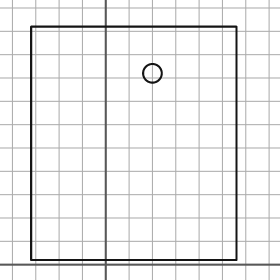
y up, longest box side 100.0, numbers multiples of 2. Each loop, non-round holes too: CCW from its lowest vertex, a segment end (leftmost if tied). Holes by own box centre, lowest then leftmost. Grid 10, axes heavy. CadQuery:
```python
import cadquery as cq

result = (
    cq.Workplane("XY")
    .moveTo(-32.0, 2.0)
    .lineTo(56.0, 2.0)
    .lineTo(56.0, 102.0)
    .lineTo(-32.0, 102.0)
    .close()
    .moveTo(20.0, 82.0)
    .circle(4.0)
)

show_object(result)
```